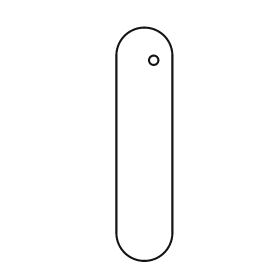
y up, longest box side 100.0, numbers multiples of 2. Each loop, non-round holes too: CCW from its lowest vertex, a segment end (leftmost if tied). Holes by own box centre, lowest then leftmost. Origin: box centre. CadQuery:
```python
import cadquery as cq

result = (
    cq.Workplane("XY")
    .moveTo(-12.0, -38.0)
    .threePointArc((0.0, -50.0), (12.0, -38.0))
    .lineTo(12.0, 38.0)
    .threePointArc((0.0, 50.0), (-12.0, 38.0))
    .close()
    .moveTo(4.0, 36.0)
    .circle(2.0)
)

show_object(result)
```